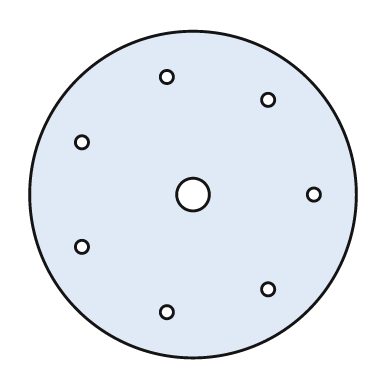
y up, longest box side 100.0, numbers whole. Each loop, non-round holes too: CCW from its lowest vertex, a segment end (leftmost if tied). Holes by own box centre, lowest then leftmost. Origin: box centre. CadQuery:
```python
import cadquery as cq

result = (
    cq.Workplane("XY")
    .moveTo(0.0, 0.0)
    .circle(50.0)
    .moveTo(-8.0, -36.0)
    .circle(2.0)
    .moveTo(23.0, -29.0)
    .circle(2.0)
    .moveTo(-34.0, -16.0)
    .circle(2.0)
    .moveTo(0.0, 0.0)
    .circle(5.0)
    .moveTo(37.0, 0.0)
    .circle(2.0)
    .moveTo(-34.0, 16.0)
    .circle(2.0)
    .moveTo(23.0, 29.0)
    .circle(2.0)
    .moveTo(-8.0, 36.0)
    .circle(2.0)
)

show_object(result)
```